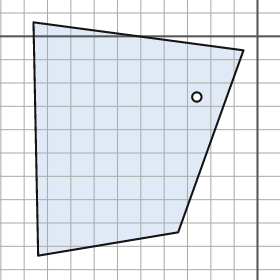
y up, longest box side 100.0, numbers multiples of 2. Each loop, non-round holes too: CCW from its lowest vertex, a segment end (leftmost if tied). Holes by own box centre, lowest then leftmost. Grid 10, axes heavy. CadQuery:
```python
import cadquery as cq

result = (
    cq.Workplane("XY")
    .moveTo(-94.0, -94.0)
    .lineTo(-34.0, -84.0)
    .lineTo(-6.0, -6.0)
    .lineTo(-96.0, 6.0)
    .close()
    .moveTo(-26.0, -26.0)
    .circle(2.0)
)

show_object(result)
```